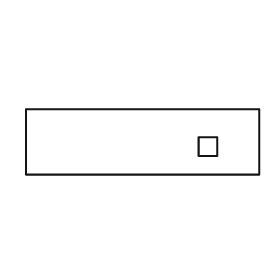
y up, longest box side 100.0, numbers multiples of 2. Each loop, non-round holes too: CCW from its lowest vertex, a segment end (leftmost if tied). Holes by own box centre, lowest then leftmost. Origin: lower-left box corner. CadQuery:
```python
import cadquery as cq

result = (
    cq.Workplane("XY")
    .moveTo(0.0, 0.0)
    .lineTo(100.0, 0.0)
    .lineTo(100.0, 28.0)
    .lineTo(0.0, 28.0)
    .close()
    .moveTo(74.0, 8.0)
    .lineTo(82.0, 8.0)
    .lineTo(82.0, 16.0)
    .lineTo(74.0, 16.0)
    .close()
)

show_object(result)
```